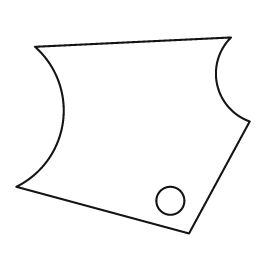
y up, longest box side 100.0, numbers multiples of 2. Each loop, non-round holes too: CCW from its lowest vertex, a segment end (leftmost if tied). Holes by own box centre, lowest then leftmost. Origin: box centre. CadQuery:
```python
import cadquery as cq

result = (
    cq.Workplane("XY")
    .moveTo(24.0, -42.0)
    .lineTo(50.0, 6.0)
    .threePointArc((36.0, 22.0), (42.0, 42.0))
    .lineTo(-42.0, 38.0)
    .threePointArc((-30.0, 6.0), (-50.0, -22.0))
    .close()
    .moveTo(16.0, -28.0)
    .circle(6.0)
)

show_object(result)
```